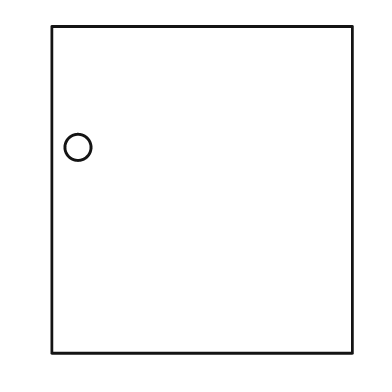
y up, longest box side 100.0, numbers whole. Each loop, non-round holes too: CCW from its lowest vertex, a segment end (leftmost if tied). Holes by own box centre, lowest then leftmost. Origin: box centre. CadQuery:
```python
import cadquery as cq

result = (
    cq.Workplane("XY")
    .moveTo(-46.0, -50.0)
    .lineTo(46.0, -50.0)
    .lineTo(46.0, 50.0)
    .lineTo(-46.0, 50.0)
    .close()
    .moveTo(-38.0, 13.0)
    .circle(4.0)
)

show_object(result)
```